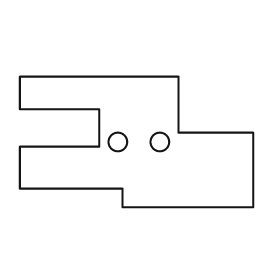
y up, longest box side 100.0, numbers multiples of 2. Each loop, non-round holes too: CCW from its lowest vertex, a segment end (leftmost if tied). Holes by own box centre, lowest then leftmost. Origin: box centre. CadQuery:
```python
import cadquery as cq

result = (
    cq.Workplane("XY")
    .moveTo(-6.0, -28.0)
    .lineTo(50.0, -28.0)
    .lineTo(50.0, 4.0)
    .lineTo(18.0, 4.0)
    .lineTo(18.0, 28.0)
    .lineTo(-50.0, 28.0)
    .lineTo(-50.0, 14.0)
    .lineTo(-16.0, 14.0)
    .lineTo(-16.0, -2.0)
    .lineTo(-50.0, -2.0)
    .lineTo(-50.0, -20.0)
    .lineTo(-6.0, -20.0)
    .close()
    .moveTo(-8.0, 0.0)
    .circle(4.0)
    .moveTo(10.0, 0.0)
    .circle(4.0)
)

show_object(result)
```